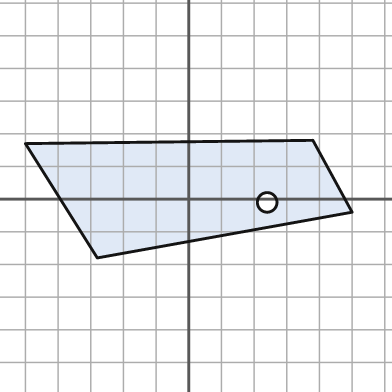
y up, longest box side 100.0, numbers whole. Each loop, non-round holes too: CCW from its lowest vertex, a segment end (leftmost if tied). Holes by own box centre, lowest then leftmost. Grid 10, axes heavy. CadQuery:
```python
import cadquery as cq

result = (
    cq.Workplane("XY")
    .moveTo(-28.0, -18.0)
    .lineTo(50.0, -4.0)
    .lineTo(38.0, 18.0)
    .lineTo(-50.0, 17.0)
    .close()
    .moveTo(24.0, -1.0)
    .circle(3.0)
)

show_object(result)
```